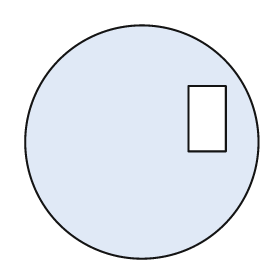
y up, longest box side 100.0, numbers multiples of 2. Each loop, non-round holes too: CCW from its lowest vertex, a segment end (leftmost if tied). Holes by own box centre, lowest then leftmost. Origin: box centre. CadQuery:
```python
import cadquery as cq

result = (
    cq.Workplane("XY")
    .moveTo(0.0, 0.0)
    .circle(50.0)
    .moveTo(20.0, -4.0)
    .lineTo(36.0, -4.0)
    .lineTo(36.0, 24.0)
    .lineTo(20.0, 24.0)
    .close()
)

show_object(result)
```